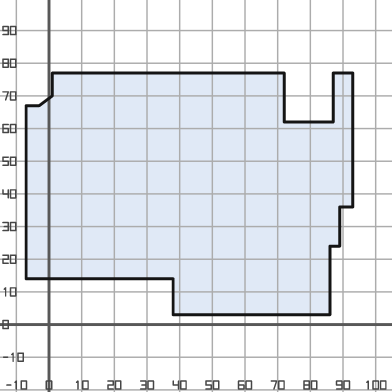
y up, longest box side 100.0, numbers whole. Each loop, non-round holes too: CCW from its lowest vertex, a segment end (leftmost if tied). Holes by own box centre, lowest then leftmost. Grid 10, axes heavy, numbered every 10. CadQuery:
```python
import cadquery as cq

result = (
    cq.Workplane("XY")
    .moveTo(38.0, 3.0)
    .lineTo(86.0, 3.0)
    .lineTo(86.0, 24.0)
    .lineTo(89.0, 24.0)
    .lineTo(89.0, 36.0)
    .lineTo(93.0, 36.0)
    .lineTo(93.0, 77.0)
    .lineTo(87.0, 77.0)
    .lineTo(87.0, 62.0)
    .lineTo(72.0, 62.0)
    .lineTo(72.0, 77.0)
    .lineTo(1.0, 77.0)
    .lineTo(1.0, 70.0)
    .lineTo(-3.0, 67.0)
    .lineTo(-7.0, 67.0)
    .lineTo(-7.0, 14.0)
    .lineTo(38.0, 14.0)
    .close()
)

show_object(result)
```